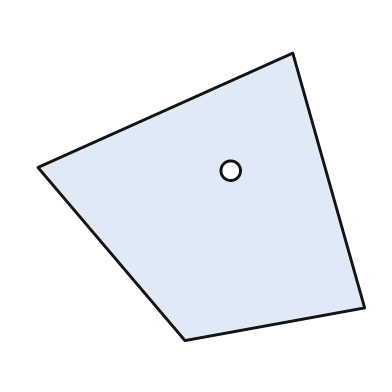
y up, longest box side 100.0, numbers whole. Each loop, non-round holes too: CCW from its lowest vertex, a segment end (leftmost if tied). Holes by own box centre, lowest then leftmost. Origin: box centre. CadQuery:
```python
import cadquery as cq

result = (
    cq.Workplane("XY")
    .moveTo(-5.0, -44.0)
    .lineTo(50.0, -34.0)
    .lineTo(28.0, 44.0)
    .lineTo(-50.0, 9.0)
    .close()
    .moveTo(9.0, 8.0)
    .circle(3.0)
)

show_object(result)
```